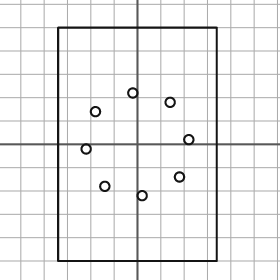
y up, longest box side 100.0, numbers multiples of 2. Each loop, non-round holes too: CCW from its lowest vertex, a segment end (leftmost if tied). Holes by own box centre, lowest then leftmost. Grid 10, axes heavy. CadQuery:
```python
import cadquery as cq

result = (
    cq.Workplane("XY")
    .moveTo(-34.0, -50.0)
    .lineTo(34.0, -50.0)
    .lineTo(34.0, 50.0)
    .lineTo(-34.0, 50.0)
    .close()
    .moveTo(2.0, -22.0)
    .circle(2.0)
    .moveTo(-14.0, -18.0)
    .circle(2.0)
    .moveTo(18.0, -14.0)
    .circle(2.0)
    .moveTo(-22.0, -2.0)
    .circle(2.0)
    .moveTo(22.0, 2.0)
    .circle(2.0)
    .moveTo(-18.0, 14.0)
    .circle(2.0)
    .moveTo(14.0, 18.0)
    .circle(2.0)
    .moveTo(-2.0, 22.0)
    .circle(2.0)
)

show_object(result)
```